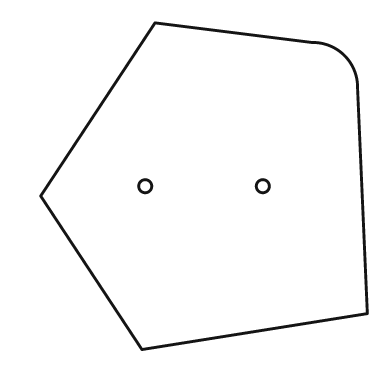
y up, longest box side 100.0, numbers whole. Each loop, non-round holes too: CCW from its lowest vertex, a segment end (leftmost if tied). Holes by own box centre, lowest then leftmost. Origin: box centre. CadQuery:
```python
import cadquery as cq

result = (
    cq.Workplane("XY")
    .moveTo(-19.0, -50.0)
    .lineTo(50.0, -39.0)
    .lineTo(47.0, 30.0)
    .threePointArc((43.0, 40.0), (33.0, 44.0))
    .lineTo(-15.0, 50.0)
    .lineTo(-50.0, -3.0)
    .close()
    .moveTo(-18.0, 0.0)
    .circle(2.0)
    .moveTo(18.0, 0.0)
    .circle(2.0)
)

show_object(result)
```